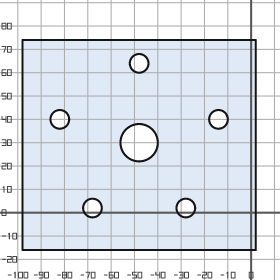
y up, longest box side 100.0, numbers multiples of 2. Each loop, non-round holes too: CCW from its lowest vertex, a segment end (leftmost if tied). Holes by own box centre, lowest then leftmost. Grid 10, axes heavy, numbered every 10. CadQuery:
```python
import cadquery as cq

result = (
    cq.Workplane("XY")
    .moveTo(-98.0, -16.0)
    .lineTo(2.0, -16.0)
    .lineTo(2.0, 74.0)
    .lineTo(-98.0, 74.0)
    .close()
    .moveTo(-68.0, 2.0)
    .circle(4.0)
    .moveTo(-28.0, 2.0)
    .circle(4.0)
    .moveTo(-48.0, 30.0)
    .circle(8.0)
    .moveTo(-82.0, 40.0)
    .circle(4.0)
    .moveTo(-14.0, 40.0)
    .circle(4.0)
    .moveTo(-48.0, 64.0)
    .circle(4.0)
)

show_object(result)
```